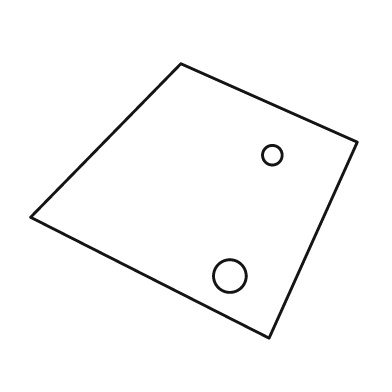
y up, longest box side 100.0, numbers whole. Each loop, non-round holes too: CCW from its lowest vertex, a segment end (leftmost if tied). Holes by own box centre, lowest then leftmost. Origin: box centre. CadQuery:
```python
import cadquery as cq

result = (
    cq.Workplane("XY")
    .moveTo(23.0, -42.0)
    .lineTo(50.0, 18.0)
    .lineTo(-4.0, 42.0)
    .lineTo(-50.0, -5.0)
    .close()
    .moveTo(11.0, -23.0)
    .circle(5.0)
    .moveTo(24.0, 14.0)
    .circle(3.0)
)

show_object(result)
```